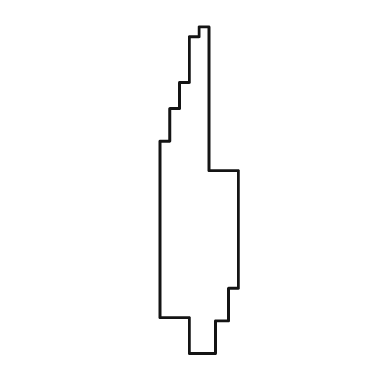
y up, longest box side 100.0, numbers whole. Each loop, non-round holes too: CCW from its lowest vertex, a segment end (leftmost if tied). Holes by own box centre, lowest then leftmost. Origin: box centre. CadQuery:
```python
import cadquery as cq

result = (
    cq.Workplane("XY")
    .moveTo(-3.0, -50.0)
    .lineTo(5.0, -50.0)
    .lineTo(5.0, -40.0)
    .lineTo(9.0, -40.0)
    .lineTo(9.0, -30.0)
    .lineTo(12.0, -30.0)
    .lineTo(12.0, 6.0)
    .lineTo(3.0, 6.0)
    .lineTo(3.0, 50.0)
    .lineTo(0.0, 50.0)
    .lineTo(0.0, 47.0)
    .lineTo(-3.0, 47.0)
    .lineTo(-3.0, 33.0)
    .lineTo(-6.0, 33.0)
    .lineTo(-6.0, 25.0)
    .lineTo(-9.0, 25.0)
    .lineTo(-9.0, 15.0)
    .lineTo(-12.0, 15.0)
    .lineTo(-12.0, -39.0)
    .lineTo(-3.0, -39.0)
    .close()
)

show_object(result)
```